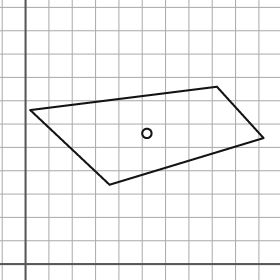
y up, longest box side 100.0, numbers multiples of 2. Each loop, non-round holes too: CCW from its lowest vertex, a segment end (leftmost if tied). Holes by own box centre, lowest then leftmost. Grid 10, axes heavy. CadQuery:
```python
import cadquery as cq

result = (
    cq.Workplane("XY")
    .moveTo(36.0, 34.0)
    .lineTo(102.0, 54.0)
    .lineTo(82.0, 76.0)
    .lineTo(2.0, 66.0)
    .close()
    .moveTo(52.0, 56.0)
    .circle(2.0)
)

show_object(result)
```